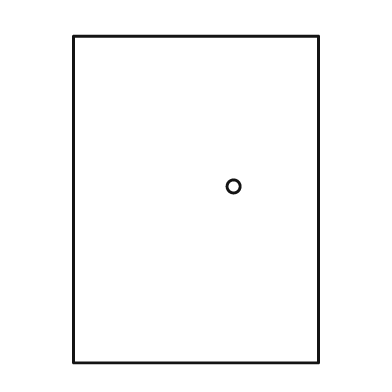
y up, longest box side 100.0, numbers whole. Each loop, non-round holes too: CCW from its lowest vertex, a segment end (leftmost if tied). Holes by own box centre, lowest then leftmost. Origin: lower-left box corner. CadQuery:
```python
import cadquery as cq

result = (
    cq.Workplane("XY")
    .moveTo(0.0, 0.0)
    .lineTo(75.0, 0.0)
    .lineTo(75.0, 100.0)
    .lineTo(0.0, 100.0)
    .close()
    .moveTo(49.0, 54.0)
    .circle(2.0)
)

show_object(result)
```